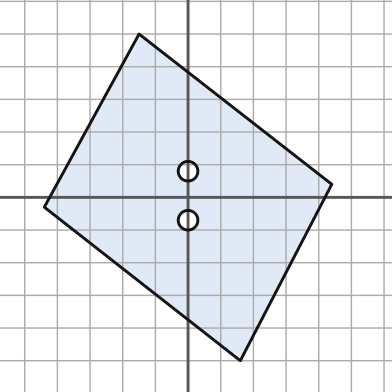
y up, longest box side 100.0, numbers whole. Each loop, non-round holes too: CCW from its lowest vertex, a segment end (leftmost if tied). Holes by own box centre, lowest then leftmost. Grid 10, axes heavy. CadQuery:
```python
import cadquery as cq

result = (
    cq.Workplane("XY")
    .moveTo(16.0, -50.0)
    .lineTo(44.0, 4.0)
    .lineTo(-15.0, 50.0)
    .lineTo(-44.0, -3.0)
    .close()
    .moveTo(0.0, -7.0)
    .circle(3.0)
    .moveTo(0.0, 8.0)
    .circle(3.0)
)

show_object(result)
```